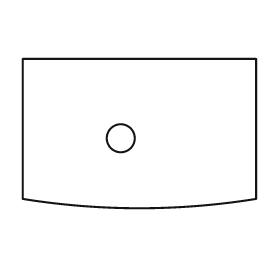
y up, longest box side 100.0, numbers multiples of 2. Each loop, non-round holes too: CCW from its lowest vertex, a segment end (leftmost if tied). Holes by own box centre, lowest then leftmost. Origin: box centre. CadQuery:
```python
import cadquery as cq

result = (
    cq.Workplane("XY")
    .moveTo(-50.0, -28.0)
    .threePointArc((0.0, -32.0), (50.0, -28.0))
    .lineTo(50.0, 32.0)
    .lineTo(-50.0, 32.0)
    .close()
    .moveTo(-8.0, -2.0)
    .circle(6.0)
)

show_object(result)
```